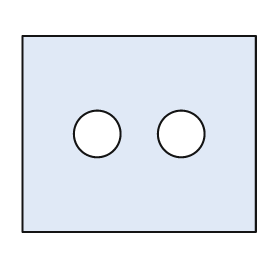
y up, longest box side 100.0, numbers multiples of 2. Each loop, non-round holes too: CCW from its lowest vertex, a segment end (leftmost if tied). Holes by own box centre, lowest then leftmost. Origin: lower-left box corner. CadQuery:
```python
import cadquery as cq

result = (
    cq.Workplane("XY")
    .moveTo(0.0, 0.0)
    .lineTo(100.0, 0.0)
    .lineTo(100.0, 84.0)
    .lineTo(0.0, 84.0)
    .close()
    .moveTo(32.0, 42.0)
    .circle(10.0)
    .moveTo(68.0, 42.0)
    .circle(10.0)
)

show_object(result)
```